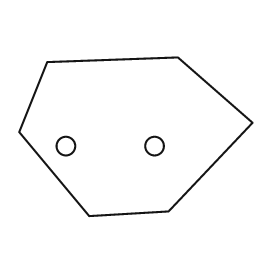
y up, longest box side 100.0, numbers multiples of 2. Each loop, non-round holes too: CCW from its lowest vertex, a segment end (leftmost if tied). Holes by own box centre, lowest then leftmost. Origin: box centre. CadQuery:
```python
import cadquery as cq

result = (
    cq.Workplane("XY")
    .moveTo(-20.0, -34.0)
    .lineTo(14.0, -32.0)
    .lineTo(50.0, 6.0)
    .lineTo(18.0, 34.0)
    .lineTo(-38.0, 32.0)
    .lineTo(-50.0, 2.0)
    .close()
    .moveTo(-30.0, -4.0)
    .circle(4.0)
    .moveTo(8.0, -4.0)
    .circle(4.0)
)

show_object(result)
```